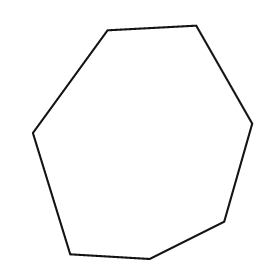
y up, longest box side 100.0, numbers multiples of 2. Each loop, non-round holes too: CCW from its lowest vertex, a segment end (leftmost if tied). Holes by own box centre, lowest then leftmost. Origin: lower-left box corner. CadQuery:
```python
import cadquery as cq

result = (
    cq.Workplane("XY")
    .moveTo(50.0, 0.0)
    .lineTo(82.0, 16.0)
    .lineTo(94.0, 58.0)
    .lineTo(70.0, 100.0)
    .lineTo(32.0, 98.0)
    .lineTo(0.0, 54.0)
    .lineTo(16.0, 2.0)
    .close()
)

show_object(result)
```